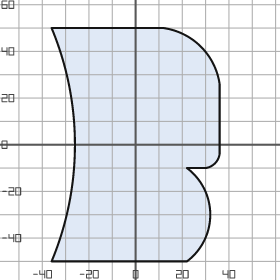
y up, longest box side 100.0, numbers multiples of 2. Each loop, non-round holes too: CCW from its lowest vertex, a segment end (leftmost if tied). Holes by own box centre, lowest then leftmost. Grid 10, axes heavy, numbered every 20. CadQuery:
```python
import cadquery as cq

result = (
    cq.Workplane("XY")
    .moveTo(-36.0, -50.0)
    .lineTo(22.0, -50.0)
    .threePointArc((32.0, -30.0), (22.0, -10.0))
    .lineTo(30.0, -10.0)
    .threePointArc((34.0, -8.0), (36.0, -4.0))
    .lineTo(36.0, 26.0)
    .threePointArc((28.0, 42.0), (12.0, 50.0))
    .lineTo(-36.0, 50.0)
    .threePointArc((-26.0, 0.0), (-36.0, -50.0))
    .close()
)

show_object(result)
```